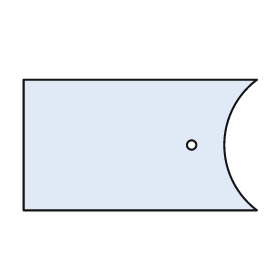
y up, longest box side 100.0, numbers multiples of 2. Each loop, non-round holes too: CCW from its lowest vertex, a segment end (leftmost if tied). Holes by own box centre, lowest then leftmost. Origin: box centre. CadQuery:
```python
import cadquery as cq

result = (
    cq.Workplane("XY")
    .moveTo(-50.0, -28.0)
    .lineTo(50.0, -28.0)
    .threePointArc((36.0, 0.0), (50.0, 28.0))
    .lineTo(-50.0, 28.0)
    .close()
    .moveTo(22.0, 0.0)
    .circle(2.0)
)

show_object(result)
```